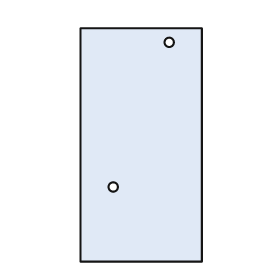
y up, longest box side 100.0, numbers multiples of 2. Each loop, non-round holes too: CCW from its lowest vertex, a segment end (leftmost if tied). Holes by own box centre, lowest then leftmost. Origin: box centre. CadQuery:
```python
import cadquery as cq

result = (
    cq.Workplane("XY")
    .moveTo(-26.0, -50.0)
    .lineTo(26.0, -50.0)
    .lineTo(26.0, 50.0)
    .lineTo(-26.0, 50.0)
    .close()
    .moveTo(-12.0, -18.0)
    .circle(2.0)
    .moveTo(12.0, 44.0)
    .circle(2.0)
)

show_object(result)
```